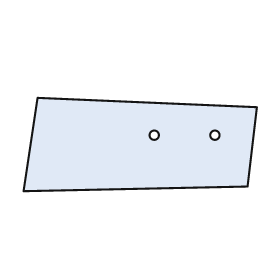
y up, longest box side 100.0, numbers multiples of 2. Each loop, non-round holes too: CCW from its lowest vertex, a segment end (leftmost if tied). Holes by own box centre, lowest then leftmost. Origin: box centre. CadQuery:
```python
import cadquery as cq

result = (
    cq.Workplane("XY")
    .moveTo(-50.0, -20.0)
    .lineTo(46.0, -18.0)
    .lineTo(50.0, 16.0)
    .lineTo(-44.0, 20.0)
    .close()
    .moveTo(6.0, 4.0)
    .circle(2.0)
    .moveTo(32.0, 4.0)
    .circle(2.0)
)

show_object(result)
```